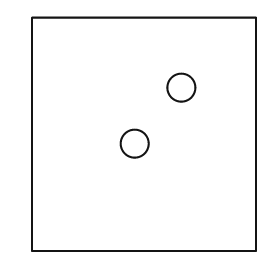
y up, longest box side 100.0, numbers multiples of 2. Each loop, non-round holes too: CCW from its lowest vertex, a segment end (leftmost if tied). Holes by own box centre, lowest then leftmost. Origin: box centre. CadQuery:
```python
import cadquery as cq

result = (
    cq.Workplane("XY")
    .moveTo(-48.0, -50.0)
    .lineTo(48.0, -50.0)
    .lineTo(48.0, 50.0)
    .lineTo(-48.0, 50.0)
    .close()
    .moveTo(-4.0, -4.0)
    .circle(6.0)
    .moveTo(16.0, 20.0)
    .circle(6.0)
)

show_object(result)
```